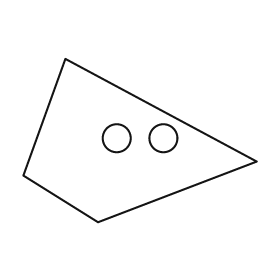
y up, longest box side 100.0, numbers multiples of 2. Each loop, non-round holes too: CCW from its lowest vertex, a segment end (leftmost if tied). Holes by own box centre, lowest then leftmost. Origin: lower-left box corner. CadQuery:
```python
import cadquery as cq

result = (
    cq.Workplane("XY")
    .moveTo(32.0, 0.0)
    .lineTo(100.0, 26.0)
    .lineTo(18.0, 70.0)
    .lineTo(0.0, 20.0)
    .close()
    .moveTo(40.0, 36.0)
    .circle(6.0)
    .moveTo(60.0, 36.0)
    .circle(6.0)
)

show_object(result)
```